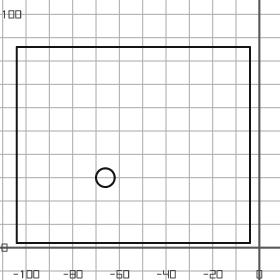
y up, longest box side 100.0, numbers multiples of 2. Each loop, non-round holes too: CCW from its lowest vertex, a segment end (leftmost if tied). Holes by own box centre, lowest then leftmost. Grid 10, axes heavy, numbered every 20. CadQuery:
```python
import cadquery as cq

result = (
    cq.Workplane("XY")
    .moveTo(-104.0, 2.0)
    .lineTo(-4.0, 2.0)
    .lineTo(-4.0, 86.0)
    .lineTo(-104.0, 86.0)
    .close()
    .moveTo(-66.0, 30.0)
    .circle(4.0)
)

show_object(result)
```